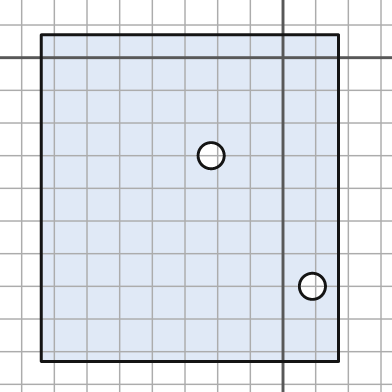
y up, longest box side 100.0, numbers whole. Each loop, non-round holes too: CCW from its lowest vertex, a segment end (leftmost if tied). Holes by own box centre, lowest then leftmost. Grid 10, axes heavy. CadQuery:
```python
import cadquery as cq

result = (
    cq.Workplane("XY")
    .moveTo(-74.0, -93.0)
    .lineTo(17.0, -93.0)
    .lineTo(17.0, 7.0)
    .lineTo(-74.0, 7.0)
    .close()
    .moveTo(9.0, -70.0)
    .circle(4.0)
    .moveTo(-22.0, -30.0)
    .circle(4.0)
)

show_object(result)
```